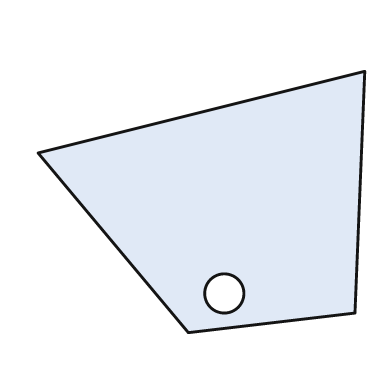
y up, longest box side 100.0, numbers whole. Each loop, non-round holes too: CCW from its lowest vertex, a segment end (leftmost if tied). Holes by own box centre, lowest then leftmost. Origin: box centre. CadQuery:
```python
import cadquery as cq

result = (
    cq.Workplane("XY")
    .moveTo(-4.0, -40.0)
    .lineTo(47.0, -34.0)
    .lineTo(50.0, 40.0)
    .lineTo(-50.0, 15.0)
    .close()
    .moveTo(7.0, -28.0)
    .circle(6.0)
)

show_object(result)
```